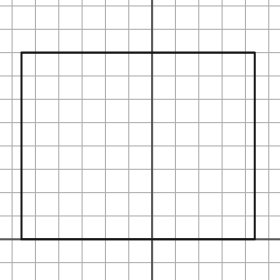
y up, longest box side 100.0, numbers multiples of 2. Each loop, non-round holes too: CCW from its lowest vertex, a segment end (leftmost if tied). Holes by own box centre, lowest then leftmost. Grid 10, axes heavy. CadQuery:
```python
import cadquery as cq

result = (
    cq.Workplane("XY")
    .moveTo(-56.0, 0.0)
    .lineTo(44.0, 0.0)
    .lineTo(44.0, 80.0)
    .lineTo(-56.0, 80.0)
    .close()
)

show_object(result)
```